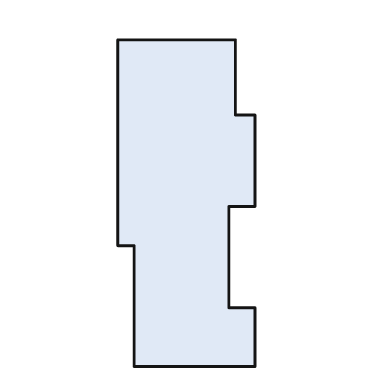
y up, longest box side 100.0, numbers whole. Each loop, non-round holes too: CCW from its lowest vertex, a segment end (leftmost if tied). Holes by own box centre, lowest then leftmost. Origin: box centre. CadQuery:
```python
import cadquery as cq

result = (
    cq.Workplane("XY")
    .moveTo(-16.0, -50.0)
    .lineTo(21.0, -50.0)
    .lineTo(21.0, -32.0)
    .lineTo(13.0, -32.0)
    .lineTo(13.0, -1.0)
    .lineTo(21.0, -1.0)
    .lineTo(21.0, 27.0)
    .lineTo(15.0, 27.0)
    .lineTo(15.0, 50.0)
    .lineTo(-21.0, 50.0)
    .lineTo(-21.0, -13.0)
    .lineTo(-16.0, -13.0)
    .close()
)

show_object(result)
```